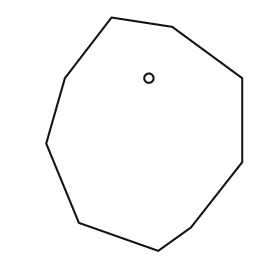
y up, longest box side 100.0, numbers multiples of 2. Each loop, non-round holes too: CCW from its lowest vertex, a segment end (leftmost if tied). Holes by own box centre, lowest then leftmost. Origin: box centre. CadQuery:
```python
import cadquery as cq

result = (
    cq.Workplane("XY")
    .moveTo(6.0, -50.0)
    .lineTo(20.0, -40.0)
    .lineTo(42.0, -12.0)
    .lineTo(42.0, 24.0)
    .lineTo(12.0, 46.0)
    .lineTo(-14.0, 50.0)
    .lineTo(-34.0, 24.0)
    .lineTo(-42.0, -4.0)
    .lineTo(-28.0, -38.0)
    .close()
    .moveTo(2.0, 24.0)
    .circle(2.0)
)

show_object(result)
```